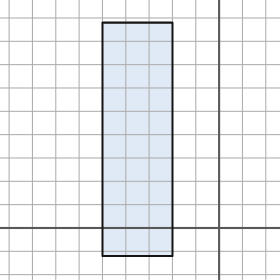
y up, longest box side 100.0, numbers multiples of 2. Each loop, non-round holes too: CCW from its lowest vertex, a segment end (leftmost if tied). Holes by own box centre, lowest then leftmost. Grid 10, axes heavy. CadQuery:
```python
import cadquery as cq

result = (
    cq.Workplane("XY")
    .moveTo(-50.0, -12.0)
    .lineTo(-20.0, -12.0)
    .lineTo(-20.0, 88.0)
    .lineTo(-50.0, 88.0)
    .close()
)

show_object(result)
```